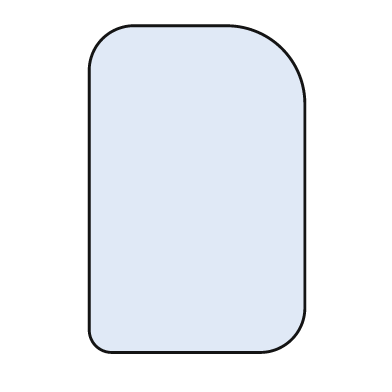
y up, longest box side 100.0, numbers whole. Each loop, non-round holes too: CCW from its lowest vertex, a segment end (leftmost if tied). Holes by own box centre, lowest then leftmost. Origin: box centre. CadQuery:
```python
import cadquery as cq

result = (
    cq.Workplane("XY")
    .moveTo(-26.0, -50.0)
    .lineTo(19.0, -50.0)
    .threePointArc((29.0, -46.0), (33.0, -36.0))
    .lineTo(33.0, 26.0)
    .threePointArc((26.0, 43.0), (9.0, 50.0))
    .lineTo(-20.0, 50.0)
    .threePointArc((-29.0, 46.0), (-33.0, 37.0))
    .lineTo(-33.0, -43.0)
    .threePointArc((-31.0, -48.0), (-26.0, -50.0))
    .close()
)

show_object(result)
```